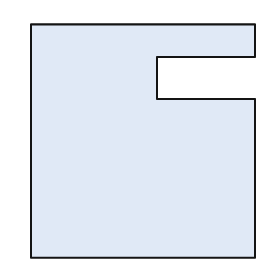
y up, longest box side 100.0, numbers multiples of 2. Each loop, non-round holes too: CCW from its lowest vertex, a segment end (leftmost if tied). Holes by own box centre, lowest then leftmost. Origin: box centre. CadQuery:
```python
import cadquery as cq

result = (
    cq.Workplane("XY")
    .moveTo(-48.0, -50.0)
    .lineTo(48.0, -50.0)
    .lineTo(48.0, 18.0)
    .lineTo(6.0, 18.0)
    .lineTo(6.0, 36.0)
    .lineTo(48.0, 36.0)
    .lineTo(48.0, 50.0)
    .lineTo(-48.0, 50.0)
    .close()
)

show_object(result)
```